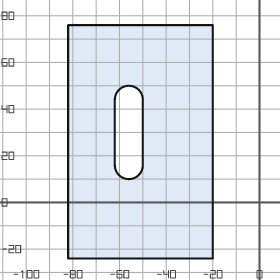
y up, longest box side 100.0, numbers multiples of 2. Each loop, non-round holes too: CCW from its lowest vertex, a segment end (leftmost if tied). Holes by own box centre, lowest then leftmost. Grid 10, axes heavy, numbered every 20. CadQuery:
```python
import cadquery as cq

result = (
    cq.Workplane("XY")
    .moveTo(-82.0, -24.0)
    .lineTo(-20.0, -24.0)
    .lineTo(-20.0, 76.0)
    .lineTo(-82.0, 76.0)
    .close()
    .moveTo(-62.0, 16.0)
    .threePointArc((-56.0, 10.0), (-50.0, 16.0))
    .lineTo(-50.0, 44.0)
    .threePointArc((-56.0, 50.0), (-62.0, 44.0))
    .close()
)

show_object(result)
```